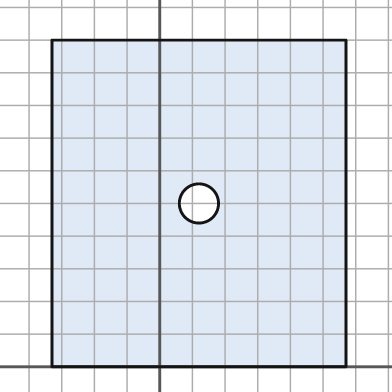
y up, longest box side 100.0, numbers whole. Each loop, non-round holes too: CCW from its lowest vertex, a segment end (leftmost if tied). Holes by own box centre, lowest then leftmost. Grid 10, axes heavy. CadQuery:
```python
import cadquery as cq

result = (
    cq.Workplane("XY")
    .moveTo(-33.0, 0.0)
    .lineTo(57.0, 0.0)
    .lineTo(57.0, 100.0)
    .lineTo(-33.0, 100.0)
    .close()
    .moveTo(12.0, 50.0)
    .circle(6.0)
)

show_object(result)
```